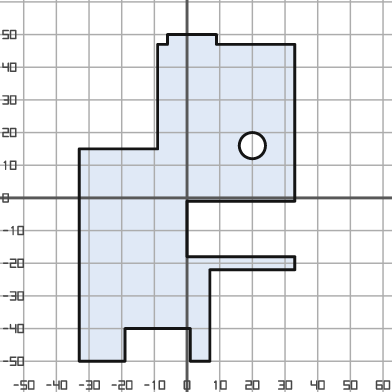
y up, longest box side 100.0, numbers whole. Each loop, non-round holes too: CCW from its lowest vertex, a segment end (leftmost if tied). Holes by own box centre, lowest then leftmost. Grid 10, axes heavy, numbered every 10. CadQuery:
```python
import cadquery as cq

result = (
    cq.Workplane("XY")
    .moveTo(-33.0, -50.0)
    .lineTo(-19.0, -50.0)
    .lineTo(-19.0, -40.0)
    .lineTo(1.0, -40.0)
    .lineTo(1.0, -50.0)
    .lineTo(7.0, -50.0)
    .lineTo(7.0, -22.0)
    .lineTo(33.0, -22.0)
    .lineTo(33.0, -18.0)
    .lineTo(0.0, -18.0)
    .lineTo(0.0, -1.0)
    .lineTo(33.0, -1.0)
    .lineTo(33.0, 47.0)
    .lineTo(9.0, 47.0)
    .lineTo(9.0, 50.0)
    .lineTo(-6.0, 50.0)
    .lineTo(-6.0, 47.0)
    .lineTo(-9.0, 47.0)
    .lineTo(-9.0, 15.0)
    .lineTo(-33.0, 15.0)
    .close()
    .moveTo(20.0, 16.0)
    .circle(4.0)
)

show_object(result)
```